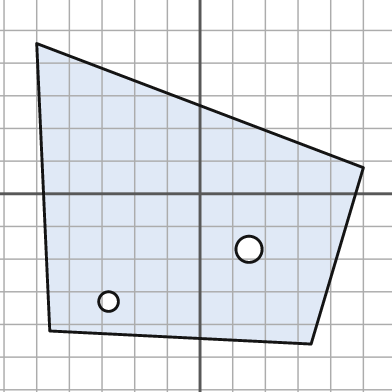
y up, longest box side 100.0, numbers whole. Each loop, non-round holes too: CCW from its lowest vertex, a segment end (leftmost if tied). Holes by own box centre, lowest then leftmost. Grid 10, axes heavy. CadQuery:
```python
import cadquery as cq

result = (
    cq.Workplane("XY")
    .moveTo(34.0, -46.0)
    .lineTo(50.0, 8.0)
    .lineTo(-50.0, 46.0)
    .lineTo(-46.0, -42.0)
    .close()
    .moveTo(-28.0, -33.0)
    .circle(3.0)
    .moveTo(15.0, -17.0)
    .circle(4.0)
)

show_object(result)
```